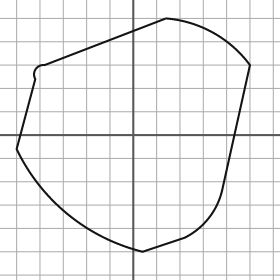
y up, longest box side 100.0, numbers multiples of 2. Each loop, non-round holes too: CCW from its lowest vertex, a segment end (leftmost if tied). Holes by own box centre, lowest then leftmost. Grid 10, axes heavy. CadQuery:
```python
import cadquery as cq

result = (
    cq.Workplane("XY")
    .moveTo(4.0, -50.0)
    .lineTo(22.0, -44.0)
    .threePointArc((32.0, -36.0), (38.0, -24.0))
    .lineTo(50.0, 30.0)
    .threePointArc((34.0, 44.0), (14.0, 50.0))
    .lineTo(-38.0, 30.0)
    .threePointArc((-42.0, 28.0), (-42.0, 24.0))
    .lineTo(-50.0, -6.0)
    .threePointArc((-28.0, -34.0), (4.0, -50.0))
    .close()
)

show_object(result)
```